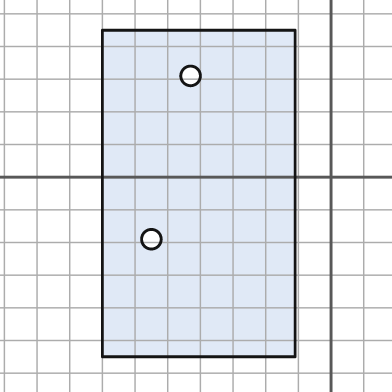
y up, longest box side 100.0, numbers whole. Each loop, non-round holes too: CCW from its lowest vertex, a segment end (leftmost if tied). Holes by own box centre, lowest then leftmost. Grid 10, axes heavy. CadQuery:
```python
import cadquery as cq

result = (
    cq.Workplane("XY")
    .moveTo(-70.0, -55.0)
    .lineTo(-11.0, -55.0)
    .lineTo(-11.0, 45.0)
    .lineTo(-70.0, 45.0)
    .close()
    .moveTo(-55.0, -19.0)
    .circle(3.0)
    .moveTo(-43.0, 31.0)
    .circle(3.0)
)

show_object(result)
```